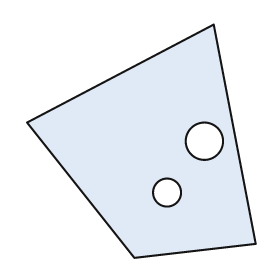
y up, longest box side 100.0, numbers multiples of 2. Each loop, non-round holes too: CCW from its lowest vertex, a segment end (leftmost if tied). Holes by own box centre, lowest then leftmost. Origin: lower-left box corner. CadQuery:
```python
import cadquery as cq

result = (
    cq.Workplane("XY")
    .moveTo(46.0, 0.0)
    .lineTo(98.0, 6.0)
    .lineTo(80.0, 100.0)
    .lineTo(0.0, 58.0)
    .close()
    .moveTo(60.0, 28.0)
    .circle(6.0)
    .moveTo(76.0, 50.0)
    .circle(8.0)
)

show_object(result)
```